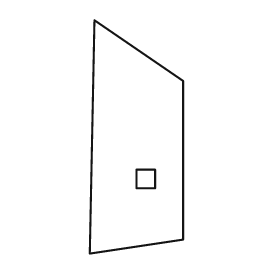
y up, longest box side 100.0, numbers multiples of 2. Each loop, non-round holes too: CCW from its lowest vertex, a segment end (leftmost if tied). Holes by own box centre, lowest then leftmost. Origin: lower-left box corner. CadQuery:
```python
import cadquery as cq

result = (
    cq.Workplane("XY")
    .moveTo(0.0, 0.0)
    .lineTo(40.0, 6.0)
    .lineTo(40.0, 74.0)
    .lineTo(2.0, 100.0)
    .close()
    .moveTo(20.0, 28.0)
    .lineTo(28.0, 28.0)
    .lineTo(28.0, 36.0)
    .lineTo(20.0, 36.0)
    .close()
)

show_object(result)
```